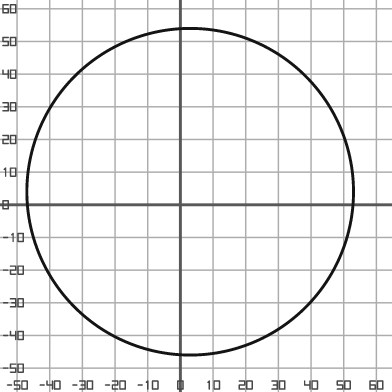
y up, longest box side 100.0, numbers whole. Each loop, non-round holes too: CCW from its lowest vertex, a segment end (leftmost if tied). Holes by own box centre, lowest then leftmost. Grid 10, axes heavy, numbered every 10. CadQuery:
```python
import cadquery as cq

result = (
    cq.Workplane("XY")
    .moveTo(3.0, 4.0)
    .circle(50.0)
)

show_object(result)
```